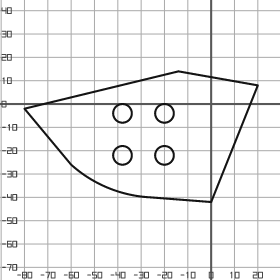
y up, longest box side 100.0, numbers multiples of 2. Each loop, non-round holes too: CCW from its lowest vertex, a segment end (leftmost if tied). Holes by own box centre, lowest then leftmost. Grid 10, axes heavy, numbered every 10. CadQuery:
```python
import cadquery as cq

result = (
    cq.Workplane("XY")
    .moveTo(0.0, -42.0)
    .lineTo(20.0, 8.0)
    .lineTo(-14.0, 14.0)
    .lineTo(-80.0, -2.0)
    .lineTo(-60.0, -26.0)
    .threePointArc((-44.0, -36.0), (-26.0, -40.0))
    .close()
    .moveTo(-38.0, -22.0)
    .circle(4.0)
    .moveTo(-20.0, -22.0)
    .circle(4.0)
    .moveTo(-38.0, -4.0)
    .circle(4.0)
    .moveTo(-20.0, -4.0)
    .circle(4.0)
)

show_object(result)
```